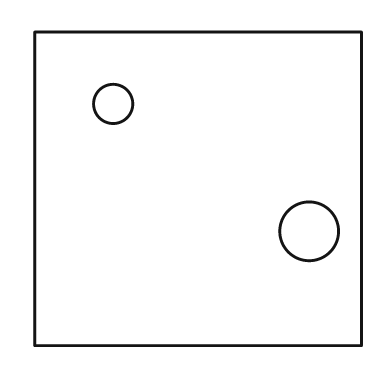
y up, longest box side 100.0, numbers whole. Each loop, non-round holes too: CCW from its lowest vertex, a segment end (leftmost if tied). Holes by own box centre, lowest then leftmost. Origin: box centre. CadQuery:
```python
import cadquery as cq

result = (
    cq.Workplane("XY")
    .moveTo(-50.0, -48.0)
    .lineTo(50.0, -48.0)
    .lineTo(50.0, 48.0)
    .lineTo(-50.0, 48.0)
    .close()
    .moveTo(34.0, -13.0)
    .circle(9.0)
    .moveTo(-26.0, 26.0)
    .circle(6.0)
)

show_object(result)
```